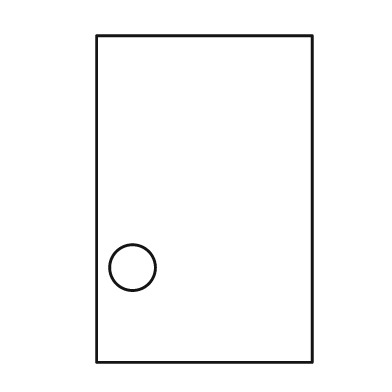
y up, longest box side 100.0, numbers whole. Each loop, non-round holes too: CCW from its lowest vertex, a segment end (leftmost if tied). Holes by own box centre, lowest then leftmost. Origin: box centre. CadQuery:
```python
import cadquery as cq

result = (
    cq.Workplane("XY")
    .moveTo(-33.0, -50.0)
    .lineTo(33.0, -50.0)
    .lineTo(33.0, 50.0)
    .lineTo(-33.0, 50.0)
    .close()
    .moveTo(-22.0, -21.0)
    .circle(7.0)
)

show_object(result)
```